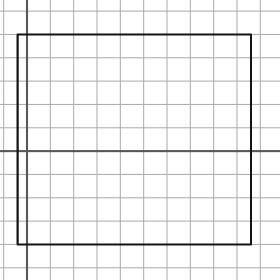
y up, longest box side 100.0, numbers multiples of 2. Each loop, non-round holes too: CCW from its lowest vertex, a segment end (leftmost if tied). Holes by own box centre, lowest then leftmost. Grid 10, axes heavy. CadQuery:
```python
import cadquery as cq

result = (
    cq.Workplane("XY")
    .moveTo(-4.0, -40.0)
    .lineTo(96.0, -40.0)
    .lineTo(96.0, 50.0)
    .lineTo(-4.0, 50.0)
    .close()
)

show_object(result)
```